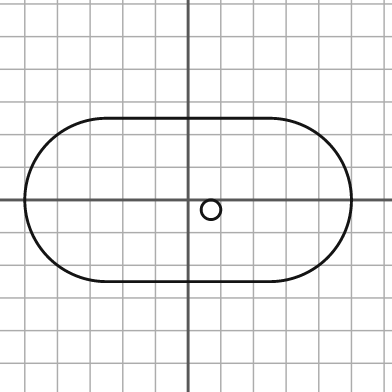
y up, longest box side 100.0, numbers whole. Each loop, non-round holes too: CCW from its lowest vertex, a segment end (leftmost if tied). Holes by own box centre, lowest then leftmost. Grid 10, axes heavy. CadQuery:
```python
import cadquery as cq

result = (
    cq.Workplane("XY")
    .moveTo(-25.0, -25.0)
    .lineTo(25.0, -25.0)
    .threePointArc((50.0, 0.0), (25.0, 25.0))
    .lineTo(-25.0, 25.0)
    .threePointArc((-50.0, 0.0), (-25.0, -25.0))
    .close()
    .moveTo(7.0, -3.0)
    .circle(3.0)
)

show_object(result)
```